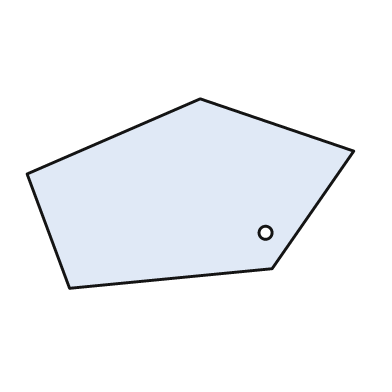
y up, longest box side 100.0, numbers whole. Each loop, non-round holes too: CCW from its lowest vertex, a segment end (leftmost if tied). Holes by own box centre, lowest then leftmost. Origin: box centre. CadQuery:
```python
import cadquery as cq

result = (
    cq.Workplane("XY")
    .moveTo(-37.0, -29.0)
    .lineTo(25.0, -23.0)
    .lineTo(50.0, 13.0)
    .lineTo(3.0, 29.0)
    .lineTo(-50.0, 6.0)
    .close()
    .moveTo(23.0, -12.0)
    .circle(2.0)
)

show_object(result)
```